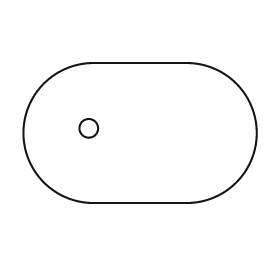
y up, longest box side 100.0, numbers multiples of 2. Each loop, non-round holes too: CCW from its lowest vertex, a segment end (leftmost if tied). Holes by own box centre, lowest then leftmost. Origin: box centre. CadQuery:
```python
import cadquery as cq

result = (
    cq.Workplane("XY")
    .moveTo(-20.0, -30.0)
    .lineTo(20.0, -30.0)
    .threePointArc((50.0, 0.0), (20.0, 30.0))
    .lineTo(-20.0, 30.0)
    .threePointArc((-50.0, 0.0), (-20.0, -30.0))
    .close()
    .moveTo(-22.0, 2.0)
    .circle(4.0)
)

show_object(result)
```